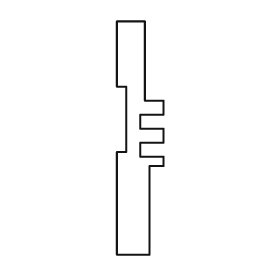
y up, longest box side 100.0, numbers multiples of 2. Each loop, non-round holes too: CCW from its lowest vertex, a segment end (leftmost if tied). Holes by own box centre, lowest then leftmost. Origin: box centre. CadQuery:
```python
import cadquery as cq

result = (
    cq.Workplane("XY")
    .moveTo(-10.0, -50.0)
    .lineTo(4.0, -50.0)
    .lineTo(4.0, -12.0)
    .lineTo(10.0, -12.0)
    .lineTo(10.0, -8.0)
    .lineTo(0.0, -8.0)
    .lineTo(0.0, -2.0)
    .lineTo(10.0, -2.0)
    .lineTo(10.0, 4.0)
    .lineTo(0.0, 4.0)
    .lineTo(0.0, 10.0)
    .lineTo(10.0, 10.0)
    .lineTo(10.0, 16.0)
    .lineTo(2.0, 16.0)
    .lineTo(2.0, 50.0)
    .lineTo(-10.0, 50.0)
    .lineTo(-10.0, 22.0)
    .lineTo(-6.0, 22.0)
    .lineTo(-6.0, -6.0)
    .lineTo(-10.0, -6.0)
    .close()
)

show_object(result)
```